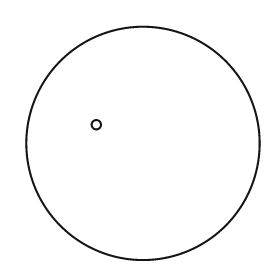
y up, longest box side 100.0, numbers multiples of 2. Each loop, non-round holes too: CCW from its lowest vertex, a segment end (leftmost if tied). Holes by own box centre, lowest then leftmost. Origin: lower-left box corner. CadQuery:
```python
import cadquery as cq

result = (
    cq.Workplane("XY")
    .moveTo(50.0, 50.0)
    .circle(50.0)
    .moveTo(30.0, 58.0)
    .circle(2.0)
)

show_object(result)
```